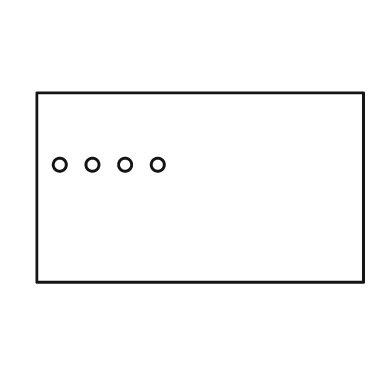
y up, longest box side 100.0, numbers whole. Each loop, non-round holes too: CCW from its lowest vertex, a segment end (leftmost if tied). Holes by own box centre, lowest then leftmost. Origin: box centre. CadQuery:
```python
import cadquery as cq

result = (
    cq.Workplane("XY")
    .moveTo(-50.0, -29.0)
    .lineTo(50.0, -29.0)
    .lineTo(50.0, 29.0)
    .lineTo(-50.0, 29.0)
    .close()
    .moveTo(-43.0, 7.0)
    .circle(2.0)
    .moveTo(-33.0, 7.0)
    .circle(2.0)
    .moveTo(-23.0, 7.0)
    .circle(2.0)
    .moveTo(-13.0, 7.0)
    .circle(2.0)
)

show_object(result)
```